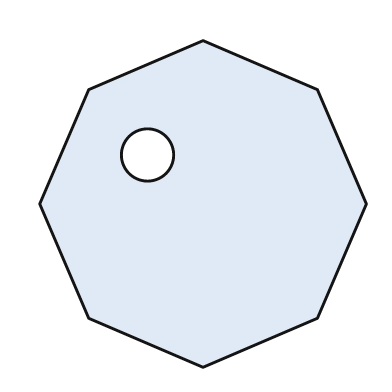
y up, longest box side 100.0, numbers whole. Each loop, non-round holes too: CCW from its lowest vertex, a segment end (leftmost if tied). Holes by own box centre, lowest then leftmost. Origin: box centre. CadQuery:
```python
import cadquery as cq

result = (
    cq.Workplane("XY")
    .moveTo(0.0, -50.0)
    .lineTo(35.0, -35.0)
    .lineTo(50.0, 0.0)
    .lineTo(35.0, 35.0)
    .lineTo(0.0, 50.0)
    .lineTo(-35.0, 35.0)
    .lineTo(-50.0, 0.0)
    .lineTo(-35.0, -35.0)
    .close()
    .moveTo(-17.0, 15.0)
    .circle(8.0)
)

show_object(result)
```